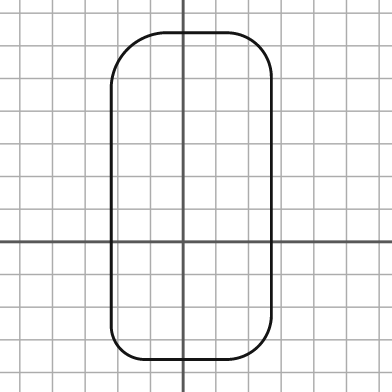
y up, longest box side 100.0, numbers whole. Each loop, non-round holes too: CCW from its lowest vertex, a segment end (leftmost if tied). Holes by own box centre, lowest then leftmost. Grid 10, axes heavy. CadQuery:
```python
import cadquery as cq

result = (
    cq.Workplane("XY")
    .moveTo(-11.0, -36.0)
    .lineTo(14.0, -36.0)
    .threePointArc((23.0, -32.0), (27.0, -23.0))
    .lineTo(27.0, 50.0)
    .threePointArc((23.0, 60.0), (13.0, 64.0))
    .lineTo(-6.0, 64.0)
    .threePointArc((-17.0, 59.0), (-22.0, 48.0))
    .lineTo(-22.0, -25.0)
    .threePointArc((-19.0, -33.0), (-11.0, -36.0))
    .close()
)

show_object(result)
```